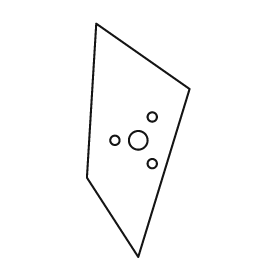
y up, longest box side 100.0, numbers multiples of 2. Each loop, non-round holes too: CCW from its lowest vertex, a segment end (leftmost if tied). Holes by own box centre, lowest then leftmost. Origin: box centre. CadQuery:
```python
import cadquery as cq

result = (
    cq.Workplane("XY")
    .moveTo(0.0, -50.0)
    .lineTo(22.0, 22.0)
    .lineTo(-18.0, 50.0)
    .lineTo(-22.0, -16.0)
    .close()
    .moveTo(6.0, -10.0)
    .circle(2.0)
    .moveTo(-10.0, 0.0)
    .circle(2.0)
    .moveTo(0.0, 0.0)
    .circle(4.0)
    .moveTo(6.0, 10.0)
    .circle(2.0)
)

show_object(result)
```